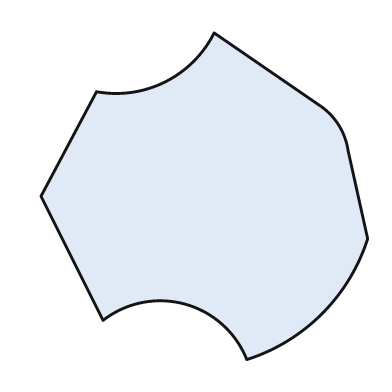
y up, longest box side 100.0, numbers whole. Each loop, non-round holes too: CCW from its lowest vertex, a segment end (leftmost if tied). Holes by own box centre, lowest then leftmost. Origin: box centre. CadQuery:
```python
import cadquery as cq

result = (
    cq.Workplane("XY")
    .moveTo(13.0, -50.0)
    .threePointArc((36.0, -36.0), (50.0, -13.0))
    .lineTo(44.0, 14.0)
    .threePointArc((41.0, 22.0), (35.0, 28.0))
    .lineTo(3.0, 50.0)
    .threePointArc((-12.0, 35.0), (-33.0, 32.0))
    .lineTo(-50.0, 0.0)
    .lineTo(-31.0, -38.0)
    .threePointArc((-6.0, -33.0), (13.0, -50.0))
    .close()
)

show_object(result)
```